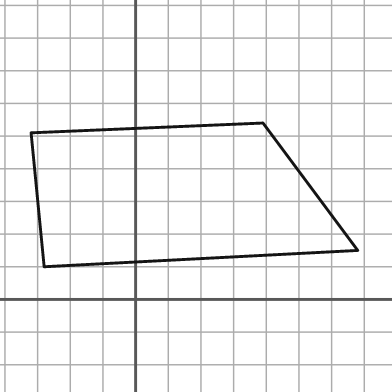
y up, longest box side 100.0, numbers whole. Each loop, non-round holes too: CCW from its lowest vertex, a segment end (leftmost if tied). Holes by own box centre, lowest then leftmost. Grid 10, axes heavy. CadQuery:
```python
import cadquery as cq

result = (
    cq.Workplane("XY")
    .moveTo(-28.0, 10.0)
    .lineTo(68.0, 15.0)
    .lineTo(39.0, 54.0)
    .lineTo(-32.0, 51.0)
    .close()
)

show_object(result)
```